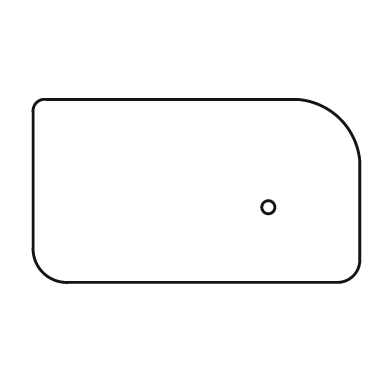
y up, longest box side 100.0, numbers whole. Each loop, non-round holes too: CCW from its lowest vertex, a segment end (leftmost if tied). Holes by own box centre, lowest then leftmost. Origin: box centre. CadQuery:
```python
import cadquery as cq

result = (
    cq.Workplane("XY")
    .moveTo(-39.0, -28.0)
    .lineTo(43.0, -28.0)
    .threePointArc((48.0, -26.0), (50.0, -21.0))
    .lineTo(50.0, 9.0)
    .threePointArc((44.0, 22.0), (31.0, 28.0))
    .lineTo(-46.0, 28.0)
    .threePointArc((-49.0, 27.0), (-50.0, 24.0))
    .lineTo(-50.0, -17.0)
    .threePointArc((-47.0, -25.0), (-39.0, -28.0))
    .close()
    .moveTo(22.0, -5.0)
    .circle(2.0)
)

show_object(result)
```